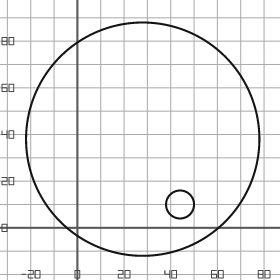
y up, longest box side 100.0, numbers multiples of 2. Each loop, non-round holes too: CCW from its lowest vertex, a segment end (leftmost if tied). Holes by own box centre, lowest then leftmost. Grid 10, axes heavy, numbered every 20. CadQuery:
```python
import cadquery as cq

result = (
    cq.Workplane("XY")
    .moveTo(28.0, 38.0)
    .circle(50.0)
    .moveTo(44.0, 10.0)
    .circle(6.0)
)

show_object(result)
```